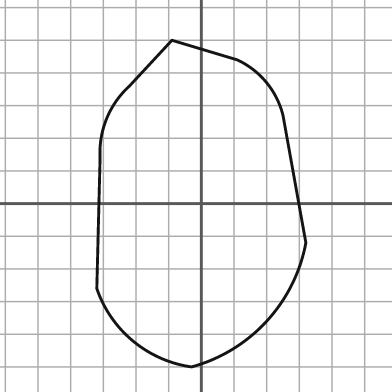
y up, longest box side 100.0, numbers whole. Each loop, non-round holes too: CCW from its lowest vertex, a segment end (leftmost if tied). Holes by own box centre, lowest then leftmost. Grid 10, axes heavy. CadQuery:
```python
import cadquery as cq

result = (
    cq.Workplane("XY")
    .moveTo(-3.0, -50.0)
    .threePointArc((20.0, -36.0), (32.0, -12.0))
    .lineTo(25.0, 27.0)
    .threePointArc((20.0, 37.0), (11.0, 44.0))
    .lineTo(-9.0, 50.0)
    .lineTo(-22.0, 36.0)
    .threePointArc((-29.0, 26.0), (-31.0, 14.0))
    .lineTo(-32.0, -26.0)
    .threePointArc((-21.0, -42.0), (-3.0, -50.0))
    .close()
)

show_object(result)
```